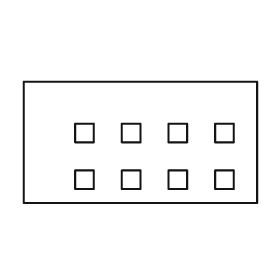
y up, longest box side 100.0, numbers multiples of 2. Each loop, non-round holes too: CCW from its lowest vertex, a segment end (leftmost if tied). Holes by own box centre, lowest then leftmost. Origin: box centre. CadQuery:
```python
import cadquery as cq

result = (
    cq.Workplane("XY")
    .moveTo(-50.0, -26.0)
    .lineTo(50.0, -26.0)
    .lineTo(50.0, 26.0)
    .lineTo(-50.0, 26.0)
    .close()
    .moveTo(-28.0, -20.0)
    .lineTo(-20.0, -20.0)
    .lineTo(-20.0, -12.0)
    .lineTo(-28.0, -12.0)
    .close()
    .moveTo(-8.0, -20.0)
    .lineTo(0.0, -20.0)
    .lineTo(0.0, -12.0)
    .lineTo(-8.0, -12.0)
    .close()
    .moveTo(12.0, -20.0)
    .lineTo(20.0, -20.0)
    .lineTo(20.0, -12.0)
    .lineTo(12.0, -12.0)
    .close()
    .moveTo(32.0, -20.0)
    .lineTo(40.0, -20.0)
    .lineTo(40.0, -12.0)
    .lineTo(32.0, -12.0)
    .close()
    .moveTo(-28.0, 0.0)
    .lineTo(-20.0, 0.0)
    .lineTo(-20.0, 8.0)
    .lineTo(-28.0, 8.0)
    .close()
    .moveTo(-8.0, 0.0)
    .lineTo(0.0, 0.0)
    .lineTo(0.0, 8.0)
    .lineTo(-8.0, 8.0)
    .close()
    .moveTo(12.0, 0.0)
    .lineTo(20.0, 0.0)
    .lineTo(20.0, 8.0)
    .lineTo(12.0, 8.0)
    .close()
    .moveTo(32.0, 0.0)
    .lineTo(40.0, 0.0)
    .lineTo(40.0, 8.0)
    .lineTo(32.0, 8.0)
    .close()
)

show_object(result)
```